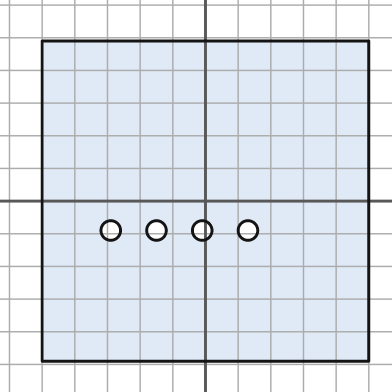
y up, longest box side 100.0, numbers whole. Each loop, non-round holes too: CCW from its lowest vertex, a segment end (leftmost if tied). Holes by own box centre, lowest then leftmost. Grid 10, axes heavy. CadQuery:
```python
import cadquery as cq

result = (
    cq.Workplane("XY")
    .moveTo(-50.0, -49.0)
    .lineTo(50.0, -49.0)
    .lineTo(50.0, 49.0)
    .lineTo(-50.0, 49.0)
    .close()
    .moveTo(-29.0, -9.0)
    .circle(3.0)
    .moveTo(-15.0, -9.0)
    .circle(3.0)
    .moveTo(-1.0, -9.0)
    .circle(3.0)
    .moveTo(13.0, -9.0)
    .circle(3.0)
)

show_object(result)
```